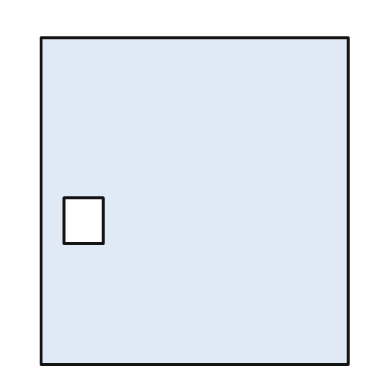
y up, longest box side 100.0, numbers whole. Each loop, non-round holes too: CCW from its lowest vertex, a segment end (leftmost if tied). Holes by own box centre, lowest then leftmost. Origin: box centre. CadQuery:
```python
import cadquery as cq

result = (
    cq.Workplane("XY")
    .moveTo(-47.0, -50.0)
    .lineTo(47.0, -50.0)
    .lineTo(47.0, 50.0)
    .lineTo(-47.0, 50.0)
    .close()
    .moveTo(-40.0, -13.0)
    .lineTo(-28.0, -13.0)
    .lineTo(-28.0, 1.0)
    .lineTo(-40.0, 1.0)
    .close()
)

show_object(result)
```